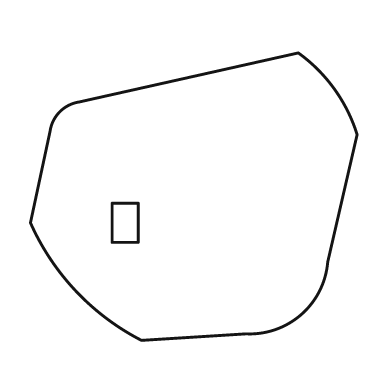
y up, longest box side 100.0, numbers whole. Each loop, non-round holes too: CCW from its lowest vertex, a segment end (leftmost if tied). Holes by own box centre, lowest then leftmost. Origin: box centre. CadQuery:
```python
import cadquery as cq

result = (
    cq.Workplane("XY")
    .moveTo(-16.0, -44.0)
    .lineTo(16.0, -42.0)
    .threePointArc((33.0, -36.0), (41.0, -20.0))
    .lineTo(50.0, 19.0)
    .threePointArc((43.0, 33.0), (32.0, 44.0))
    .lineTo(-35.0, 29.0)
    .threePointArc((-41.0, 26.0), (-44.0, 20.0))
    .lineTo(-50.0, -8.0)
    .threePointArc((-36.0, -29.0), (-16.0, -44.0))
    .close()
    .moveTo(-25.0, -14.0)
    .lineTo(-17.0, -14.0)
    .lineTo(-17.0, -2.0)
    .lineTo(-25.0, -2.0)
    .close()
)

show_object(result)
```